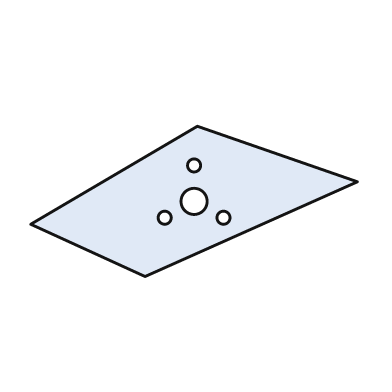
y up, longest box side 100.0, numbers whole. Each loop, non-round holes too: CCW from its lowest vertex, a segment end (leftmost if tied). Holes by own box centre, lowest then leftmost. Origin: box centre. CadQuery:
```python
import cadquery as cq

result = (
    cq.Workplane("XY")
    .moveTo(-15.0, -23.0)
    .lineTo(50.0, 6.0)
    .lineTo(1.0, 23.0)
    .lineTo(-50.0, -7.0)
    .close()
    .moveTo(-9.0, -5.0)
    .circle(2.0)
    .moveTo(9.0, -5.0)
    .circle(2.0)
    .moveTo(0.0, 0.0)
    .circle(4.0)
    .moveTo(0.0, 11.0)
    .circle(2.0)
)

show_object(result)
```